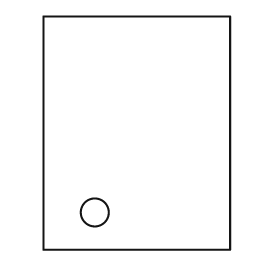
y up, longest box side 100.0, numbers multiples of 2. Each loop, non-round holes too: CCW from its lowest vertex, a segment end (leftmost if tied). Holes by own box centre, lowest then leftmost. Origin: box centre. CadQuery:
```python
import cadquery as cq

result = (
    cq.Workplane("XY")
    .moveTo(-40.0, -50.0)
    .lineTo(40.0, -50.0)
    .lineTo(40.0, 50.0)
    .lineTo(-40.0, 50.0)
    .close()
    .moveTo(-18.0, -34.0)
    .circle(6.0)
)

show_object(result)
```